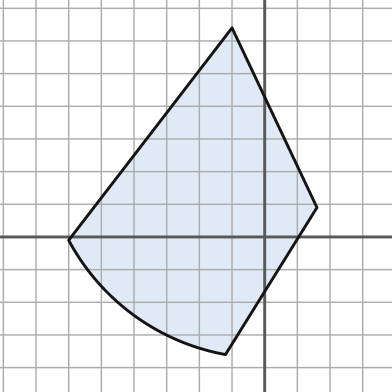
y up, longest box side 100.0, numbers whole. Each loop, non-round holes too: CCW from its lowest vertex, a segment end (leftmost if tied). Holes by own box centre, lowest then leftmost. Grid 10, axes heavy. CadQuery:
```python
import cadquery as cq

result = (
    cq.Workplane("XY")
    .moveTo(-12.0, -36.0)
    .lineTo(16.0, 9.0)
    .lineTo(-10.0, 64.0)
    .lineTo(-60.0, -1.0)
    .threePointArc((-40.0, -24.0), (-12.0, -36.0))
    .close()
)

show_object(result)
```